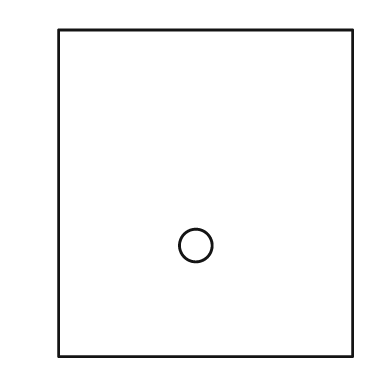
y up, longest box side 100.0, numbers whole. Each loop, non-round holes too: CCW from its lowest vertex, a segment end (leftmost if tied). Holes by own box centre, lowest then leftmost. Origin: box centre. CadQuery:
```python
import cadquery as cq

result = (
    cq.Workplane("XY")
    .moveTo(-45.0, -50.0)
    .lineTo(45.0, -50.0)
    .lineTo(45.0, 50.0)
    .lineTo(-45.0, 50.0)
    .close()
    .moveTo(-3.0, -16.0)
    .circle(5.0)
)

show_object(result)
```